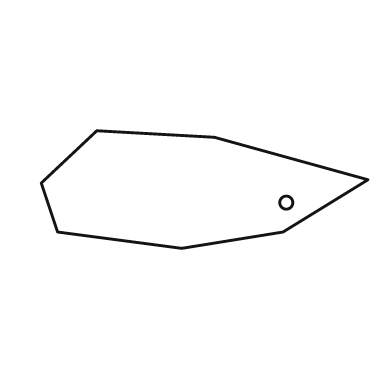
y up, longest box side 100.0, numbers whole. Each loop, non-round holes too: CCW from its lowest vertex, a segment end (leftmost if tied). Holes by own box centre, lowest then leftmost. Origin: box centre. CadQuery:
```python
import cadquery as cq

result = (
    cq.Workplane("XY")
    .moveTo(-7.0, -18.0)
    .lineTo(24.0, -13.0)
    .lineTo(50.0, 3.0)
    .lineTo(3.0, 16.0)
    .lineTo(-33.0, 18.0)
    .lineTo(-50.0, 2.0)
    .lineTo(-45.0, -13.0)
    .close()
    .moveTo(25.0, -4.0)
    .circle(2.0)
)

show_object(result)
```